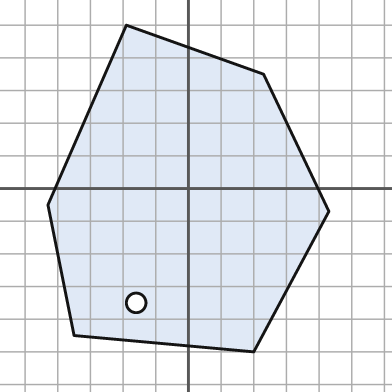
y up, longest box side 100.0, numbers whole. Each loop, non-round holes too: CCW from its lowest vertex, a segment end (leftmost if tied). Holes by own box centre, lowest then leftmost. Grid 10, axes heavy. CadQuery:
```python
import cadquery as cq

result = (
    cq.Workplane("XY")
    .moveTo(20.0, -50.0)
    .lineTo(43.0, -7.0)
    .lineTo(23.0, 35.0)
    .lineTo(-19.0, 50.0)
    .lineTo(-43.0, -5.0)
    .lineTo(-35.0, -45.0)
    .close()
    .moveTo(-16.0, -35.0)
    .circle(3.0)
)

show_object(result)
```